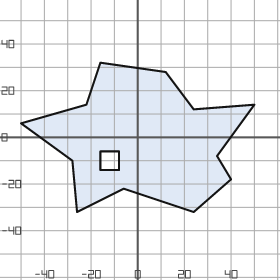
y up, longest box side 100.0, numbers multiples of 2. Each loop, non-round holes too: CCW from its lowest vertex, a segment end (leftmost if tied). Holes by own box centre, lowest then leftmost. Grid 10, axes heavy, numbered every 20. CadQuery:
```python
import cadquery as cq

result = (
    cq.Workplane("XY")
    .moveTo(-26.0, -32.0)
    .lineTo(-6.0, -22.0)
    .lineTo(24.0, -32.0)
    .lineTo(40.0, -18.0)
    .lineTo(34.0, -8.0)
    .lineTo(50.0, 14.0)
    .lineTo(24.0, 12.0)
    .lineTo(12.0, 28.0)
    .lineTo(-16.0, 32.0)
    .lineTo(-22.0, 14.0)
    .lineTo(-50.0, 6.0)
    .lineTo(-28.0, -10.0)
    .close()
    .moveTo(-16.0, -14.0)
    .lineTo(-8.0, -14.0)
    .lineTo(-8.0, -6.0)
    .lineTo(-16.0, -6.0)
    .close()
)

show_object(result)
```